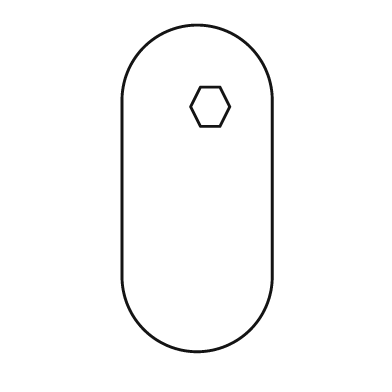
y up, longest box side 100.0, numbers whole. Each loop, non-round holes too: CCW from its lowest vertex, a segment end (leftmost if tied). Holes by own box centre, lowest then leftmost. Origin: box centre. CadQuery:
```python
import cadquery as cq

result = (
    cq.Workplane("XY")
    .moveTo(-23.0, -27.0)
    .threePointArc((0.0, -50.0), (23.0, -27.0))
    .lineTo(23.0, 27.0)
    .threePointArc((0.0, 50.0), (-23.0, 27.0))
    .close()
    .moveTo(1.0, 19.0)
    .lineTo(7.0, 19.0)
    .lineTo(10.0, 25.0)
    .lineTo(7.0, 31.0)
    .lineTo(1.0, 31.0)
    .lineTo(-2.0, 25.0)
    .close()
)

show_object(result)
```